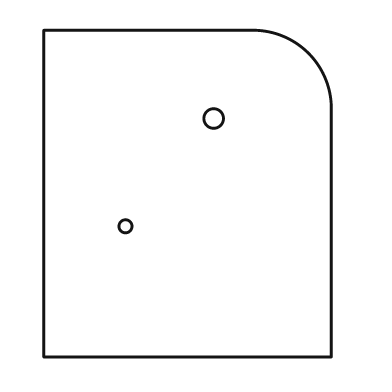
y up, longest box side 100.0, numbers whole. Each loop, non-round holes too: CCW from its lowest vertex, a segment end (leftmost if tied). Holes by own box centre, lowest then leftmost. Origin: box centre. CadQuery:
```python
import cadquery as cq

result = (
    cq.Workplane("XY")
    .moveTo(-44.0, -50.0)
    .lineTo(44.0, -50.0)
    .lineTo(44.0, 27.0)
    .threePointArc((37.0, 43.0), (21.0, 50.0))
    .lineTo(-44.0, 50.0)
    .close()
    .moveTo(-19.0, -10.0)
    .circle(2.0)
    .moveTo(8.0, 23.0)
    .circle(3.0)
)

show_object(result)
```